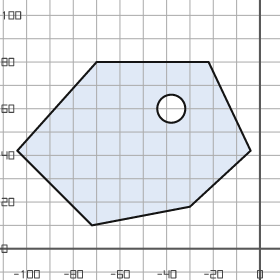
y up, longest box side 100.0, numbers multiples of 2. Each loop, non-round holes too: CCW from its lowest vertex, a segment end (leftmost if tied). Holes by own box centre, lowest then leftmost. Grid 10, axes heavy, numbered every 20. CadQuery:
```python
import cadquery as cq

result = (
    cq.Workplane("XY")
    .moveTo(-72.0, 10.0)
    .lineTo(-30.0, 18.0)
    .lineTo(-4.0, 42.0)
    .lineTo(-22.0, 80.0)
    .lineTo(-70.0, 80.0)
    .lineTo(-104.0, 42.0)
    .close()
    .moveTo(-38.0, 60.0)
    .circle(6.0)
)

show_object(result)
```